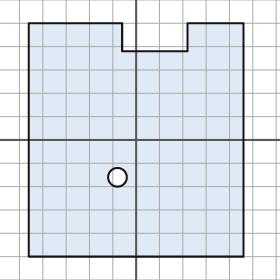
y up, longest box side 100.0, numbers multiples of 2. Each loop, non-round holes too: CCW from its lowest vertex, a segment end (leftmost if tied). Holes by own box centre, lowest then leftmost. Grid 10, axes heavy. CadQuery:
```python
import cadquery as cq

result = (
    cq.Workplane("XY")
    .moveTo(-46.0, -50.0)
    .lineTo(46.0, -50.0)
    .lineTo(46.0, 50.0)
    .lineTo(22.0, 50.0)
    .lineTo(22.0, 38.0)
    .lineTo(-6.0, 38.0)
    .lineTo(-6.0, 50.0)
    .lineTo(-46.0, 50.0)
    .close()
    .moveTo(-8.0, -16.0)
    .circle(4.0)
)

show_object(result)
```